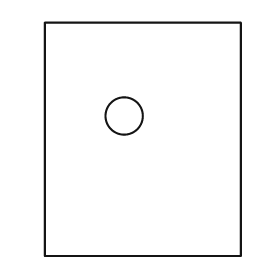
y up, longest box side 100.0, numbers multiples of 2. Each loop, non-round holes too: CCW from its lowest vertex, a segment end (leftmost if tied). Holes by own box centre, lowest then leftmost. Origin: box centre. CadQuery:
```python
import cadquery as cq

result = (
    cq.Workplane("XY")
    .moveTo(-42.0, -50.0)
    .lineTo(42.0, -50.0)
    .lineTo(42.0, 50.0)
    .lineTo(-42.0, 50.0)
    .close()
    .moveTo(-8.0, 10.0)
    .circle(8.0)
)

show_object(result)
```